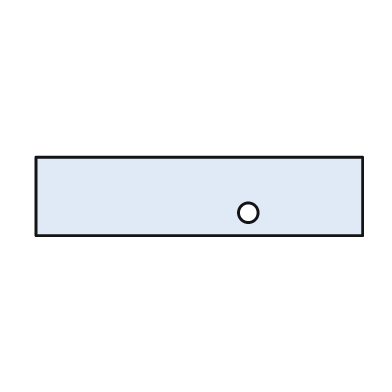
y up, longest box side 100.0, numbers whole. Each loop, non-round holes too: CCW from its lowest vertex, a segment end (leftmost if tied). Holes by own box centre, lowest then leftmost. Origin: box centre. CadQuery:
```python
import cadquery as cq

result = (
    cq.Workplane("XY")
    .moveTo(-50.0, -12.0)
    .lineTo(50.0, -12.0)
    .lineTo(50.0, 12.0)
    .lineTo(-50.0, 12.0)
    .close()
    .moveTo(15.0, -5.0)
    .circle(3.0)
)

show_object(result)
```